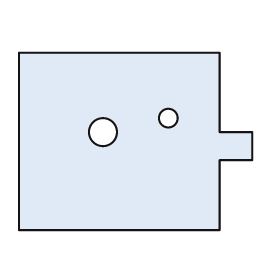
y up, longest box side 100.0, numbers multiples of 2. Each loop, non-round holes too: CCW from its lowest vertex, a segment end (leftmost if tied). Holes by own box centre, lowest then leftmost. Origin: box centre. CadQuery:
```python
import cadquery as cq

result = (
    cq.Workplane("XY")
    .moveTo(-50.0, -38.0)
    .lineTo(36.0, -38.0)
    .lineTo(36.0, -8.0)
    .lineTo(50.0, -8.0)
    .lineTo(50.0, 4.0)
    .lineTo(36.0, 4.0)
    .lineTo(36.0, 38.0)
    .lineTo(-50.0, 38.0)
    .close()
    .moveTo(-14.0, 4.0)
    .circle(6.0)
    .moveTo(14.0, 10.0)
    .circle(4.0)
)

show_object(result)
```